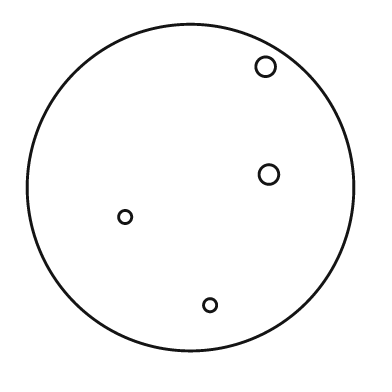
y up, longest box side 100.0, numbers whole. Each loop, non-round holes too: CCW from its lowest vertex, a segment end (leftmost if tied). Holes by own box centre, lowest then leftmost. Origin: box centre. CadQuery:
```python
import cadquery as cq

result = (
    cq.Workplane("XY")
    .moveTo(0.0, 0.0)
    .circle(50.0)
    .moveTo(6.0, -36.0)
    .circle(2.0)
    .moveTo(-20.0, -9.0)
    .circle(2.0)
    .moveTo(24.0, 4.0)
    .circle(3.0)
    .moveTo(23.0, 37.0)
    .circle(3.0)
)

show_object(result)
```